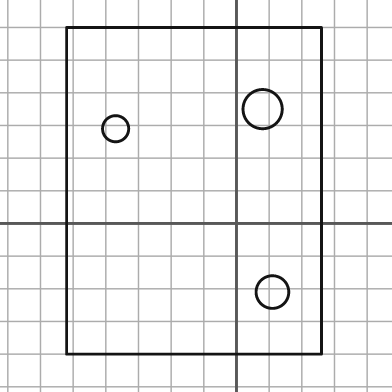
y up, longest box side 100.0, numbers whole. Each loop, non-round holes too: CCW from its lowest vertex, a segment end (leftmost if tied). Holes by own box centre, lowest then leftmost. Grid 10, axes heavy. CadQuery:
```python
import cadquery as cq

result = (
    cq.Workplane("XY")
    .moveTo(-52.0, -40.0)
    .lineTo(26.0, -40.0)
    .lineTo(26.0, 60.0)
    .lineTo(-52.0, 60.0)
    .close()
    .moveTo(11.0, -21.0)
    .circle(5.0)
    .moveTo(-37.0, 29.0)
    .circle(4.0)
    .moveTo(8.0, 35.0)
    .circle(6.0)
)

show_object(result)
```